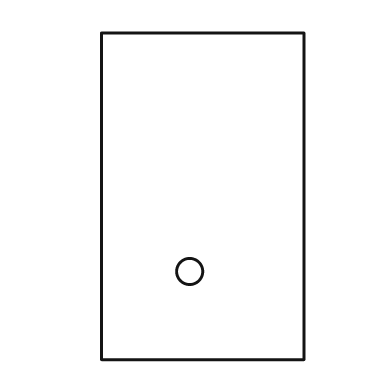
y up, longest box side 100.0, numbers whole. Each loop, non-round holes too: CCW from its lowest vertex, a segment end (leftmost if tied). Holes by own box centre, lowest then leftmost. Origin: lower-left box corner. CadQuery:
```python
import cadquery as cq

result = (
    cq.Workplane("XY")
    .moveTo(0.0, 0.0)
    .lineTo(62.0, 0.0)
    .lineTo(62.0, 100.0)
    .lineTo(0.0, 100.0)
    .close()
    .moveTo(27.0, 27.0)
    .circle(4.0)
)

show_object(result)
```